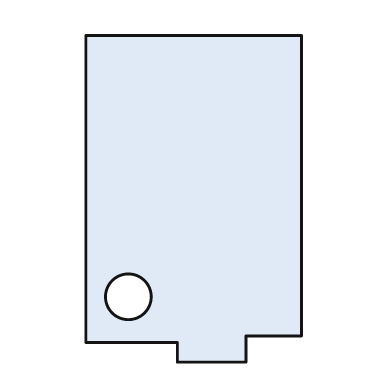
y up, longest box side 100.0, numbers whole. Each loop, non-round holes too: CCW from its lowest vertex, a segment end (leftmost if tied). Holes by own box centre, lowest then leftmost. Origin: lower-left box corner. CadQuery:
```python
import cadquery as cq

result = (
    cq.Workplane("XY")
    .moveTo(28.0, 0.0)
    .lineTo(49.0, 0.0)
    .lineTo(49.0, 8.0)
    .lineTo(66.0, 8.0)
    .lineTo(66.0, 100.0)
    .lineTo(0.0, 100.0)
    .lineTo(0.0, 6.0)
    .lineTo(28.0, 6.0)
    .close()
    .moveTo(13.0, 20.0)
    .circle(7.0)
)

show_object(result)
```